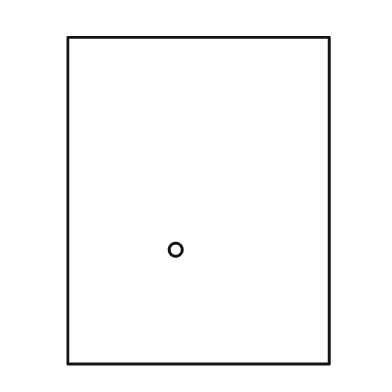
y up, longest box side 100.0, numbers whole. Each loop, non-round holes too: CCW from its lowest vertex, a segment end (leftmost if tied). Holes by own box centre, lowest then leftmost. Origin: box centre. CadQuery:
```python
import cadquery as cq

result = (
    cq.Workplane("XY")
    .moveTo(-40.0, -50.0)
    .lineTo(40.0, -50.0)
    .lineTo(40.0, 50.0)
    .lineTo(-40.0, 50.0)
    .close()
    .moveTo(-7.0, -15.0)
    .circle(2.0)
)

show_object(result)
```